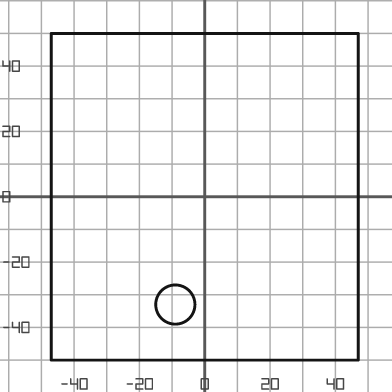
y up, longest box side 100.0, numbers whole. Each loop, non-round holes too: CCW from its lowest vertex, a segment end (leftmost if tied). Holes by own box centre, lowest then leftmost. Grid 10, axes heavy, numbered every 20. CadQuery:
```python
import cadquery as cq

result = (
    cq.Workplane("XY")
    .moveTo(-47.0, -50.0)
    .lineTo(47.0, -50.0)
    .lineTo(47.0, 50.0)
    .lineTo(-47.0, 50.0)
    .close()
    .moveTo(-9.0, -33.0)
    .circle(6.0)
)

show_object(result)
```